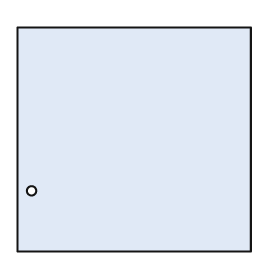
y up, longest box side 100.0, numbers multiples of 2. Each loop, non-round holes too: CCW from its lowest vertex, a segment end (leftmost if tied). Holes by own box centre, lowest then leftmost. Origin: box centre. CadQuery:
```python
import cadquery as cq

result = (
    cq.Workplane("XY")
    .moveTo(-50.0, -48.0)
    .lineTo(50.0, -48.0)
    .lineTo(50.0, 48.0)
    .lineTo(-50.0, 48.0)
    .close()
    .moveTo(-44.0, -22.0)
    .circle(2.0)
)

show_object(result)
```